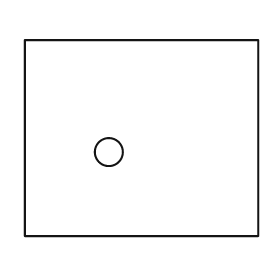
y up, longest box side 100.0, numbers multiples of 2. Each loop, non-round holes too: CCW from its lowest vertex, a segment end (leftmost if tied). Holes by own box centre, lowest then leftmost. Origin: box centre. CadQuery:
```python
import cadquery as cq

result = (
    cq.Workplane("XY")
    .moveTo(-50.0, -42.0)
    .lineTo(50.0, -42.0)
    .lineTo(50.0, 42.0)
    .lineTo(-50.0, 42.0)
    .close()
    .moveTo(-14.0, -6.0)
    .circle(6.0)
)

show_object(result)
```